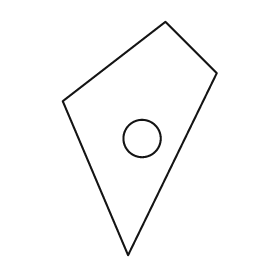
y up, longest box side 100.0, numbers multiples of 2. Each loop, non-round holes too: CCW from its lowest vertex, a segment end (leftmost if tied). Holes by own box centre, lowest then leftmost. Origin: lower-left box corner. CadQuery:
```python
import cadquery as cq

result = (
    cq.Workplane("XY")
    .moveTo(28.0, 0.0)
    .lineTo(66.0, 78.0)
    .lineTo(44.0, 100.0)
    .lineTo(0.0, 66.0)
    .close()
    .moveTo(34.0, 50.0)
    .circle(8.0)
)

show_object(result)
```